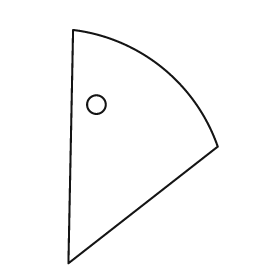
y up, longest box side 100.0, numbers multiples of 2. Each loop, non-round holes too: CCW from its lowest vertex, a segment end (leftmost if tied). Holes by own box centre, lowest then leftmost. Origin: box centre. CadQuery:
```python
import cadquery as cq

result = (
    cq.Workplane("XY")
    .moveTo(-32.0, -50.0)
    .lineTo(32.0, 0.0)
    .threePointArc((8.0, 34.0), (-30.0, 50.0))
    .close()
    .moveTo(-20.0, 18.0)
    .circle(4.0)
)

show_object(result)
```